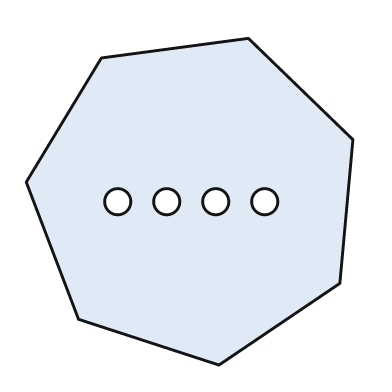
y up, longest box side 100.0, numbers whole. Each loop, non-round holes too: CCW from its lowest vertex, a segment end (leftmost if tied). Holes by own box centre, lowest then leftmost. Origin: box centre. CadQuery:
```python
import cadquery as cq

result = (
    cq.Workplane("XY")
    .moveTo(9.0, -50.0)
    .lineTo(46.0, -25.0)
    .lineTo(50.0, 19.0)
    .lineTo(18.0, 50.0)
    .lineTo(-27.0, 44.0)
    .lineTo(-50.0, 6.0)
    .lineTo(-34.0, -36.0)
    .close()
    .moveTo(-22.0, 0.0)
    .circle(4.0)
    .moveTo(-7.0, 0.0)
    .circle(4.0)
    .moveTo(8.0, 0.0)
    .circle(4.0)
    .moveTo(23.0, 0.0)
    .circle(4.0)
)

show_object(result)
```